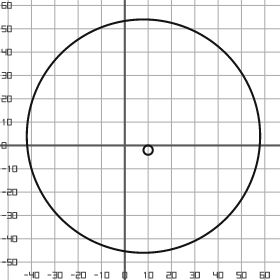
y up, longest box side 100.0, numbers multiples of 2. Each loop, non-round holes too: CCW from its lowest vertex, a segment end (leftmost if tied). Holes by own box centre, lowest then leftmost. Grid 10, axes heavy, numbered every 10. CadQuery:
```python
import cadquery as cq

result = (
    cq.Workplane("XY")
    .moveTo(8.0, 4.0)
    .circle(50.0)
    .moveTo(10.0, -2.0)
    .circle(2.0)
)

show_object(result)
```